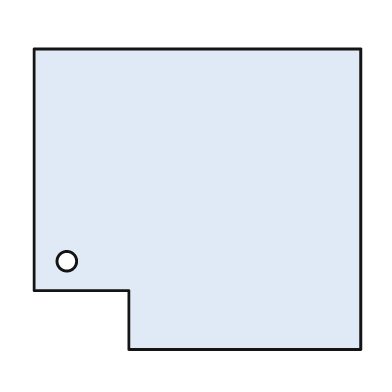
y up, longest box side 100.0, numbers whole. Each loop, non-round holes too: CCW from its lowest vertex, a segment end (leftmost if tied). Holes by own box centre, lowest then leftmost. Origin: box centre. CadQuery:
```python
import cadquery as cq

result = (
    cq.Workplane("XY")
    .moveTo(-21.0, -46.0)
    .lineTo(50.0, -46.0)
    .lineTo(50.0, 46.0)
    .lineTo(-50.0, 46.0)
    .lineTo(-50.0, -28.0)
    .lineTo(-21.0, -28.0)
    .close()
    .moveTo(-40.0, -19.0)
    .circle(3.0)
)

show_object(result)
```